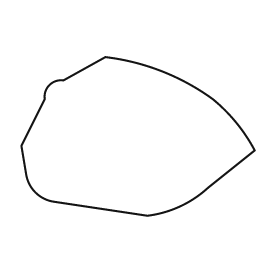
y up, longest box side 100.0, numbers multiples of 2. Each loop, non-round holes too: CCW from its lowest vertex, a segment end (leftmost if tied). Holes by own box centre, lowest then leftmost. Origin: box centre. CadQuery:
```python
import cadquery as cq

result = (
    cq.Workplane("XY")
    .moveTo(4.0, -34.0)
    .threePointArc((18.0, -30.0), (30.0, -22.0))
    .lineTo(50.0, -6.0)
    .threePointArc((42.0, 6.0), (32.0, 16.0))
    .threePointArc((10.0, 28.0), (-14.0, 34.0))
    .lineTo(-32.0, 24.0)
    .threePointArc((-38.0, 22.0), (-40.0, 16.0))
    .lineTo(-50.0, -4.0)
    .lineTo(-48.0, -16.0)
    .threePointArc((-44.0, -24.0), (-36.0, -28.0))
    .close()
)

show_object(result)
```